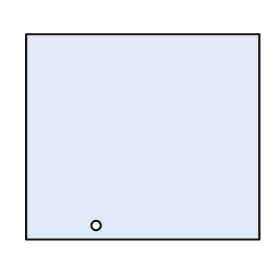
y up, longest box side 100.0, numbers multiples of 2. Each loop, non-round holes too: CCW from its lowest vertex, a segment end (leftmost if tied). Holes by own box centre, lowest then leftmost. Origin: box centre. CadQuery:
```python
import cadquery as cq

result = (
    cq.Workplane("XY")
    .moveTo(-50.0, -44.0)
    .lineTo(50.0, -44.0)
    .lineTo(50.0, 44.0)
    .lineTo(-50.0, 44.0)
    .close()
    .moveTo(-20.0, -38.0)
    .circle(2.0)
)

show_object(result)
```